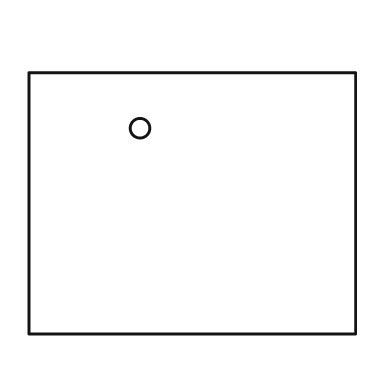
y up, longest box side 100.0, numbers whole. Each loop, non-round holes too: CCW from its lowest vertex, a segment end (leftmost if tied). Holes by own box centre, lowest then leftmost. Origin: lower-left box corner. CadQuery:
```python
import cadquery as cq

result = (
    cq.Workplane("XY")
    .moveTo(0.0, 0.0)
    .lineTo(100.0, 0.0)
    .lineTo(100.0, 80.0)
    .lineTo(0.0, 80.0)
    .close()
    .moveTo(34.0, 63.0)
    .circle(3.0)
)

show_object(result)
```